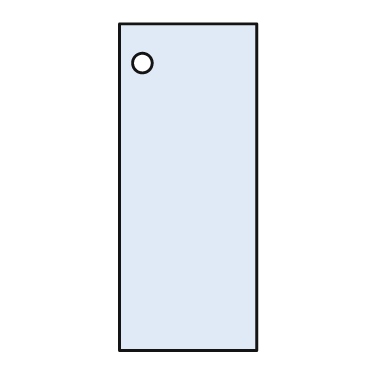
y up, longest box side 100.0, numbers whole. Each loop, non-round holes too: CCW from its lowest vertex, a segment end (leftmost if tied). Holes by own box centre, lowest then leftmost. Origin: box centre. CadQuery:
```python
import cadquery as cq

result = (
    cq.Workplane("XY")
    .moveTo(-21.0, -50.0)
    .lineTo(21.0, -50.0)
    .lineTo(21.0, 50.0)
    .lineTo(-21.0, 50.0)
    .close()
    .moveTo(-14.0, 38.0)
    .circle(3.0)
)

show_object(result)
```